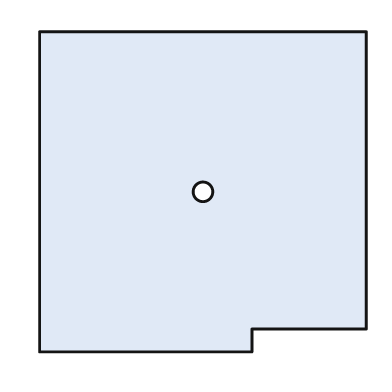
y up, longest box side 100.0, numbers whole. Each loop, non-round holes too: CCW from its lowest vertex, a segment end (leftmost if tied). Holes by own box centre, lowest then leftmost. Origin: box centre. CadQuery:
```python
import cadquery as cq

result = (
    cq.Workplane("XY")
    .moveTo(-50.0, -49.0)
    .lineTo(15.0, -49.0)
    .lineTo(15.0, -42.0)
    .lineTo(50.0, -42.0)
    .lineTo(50.0, 49.0)
    .lineTo(-50.0, 49.0)
    .close()
    .moveTo(0.0, 0.0)
    .circle(3.0)
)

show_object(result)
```